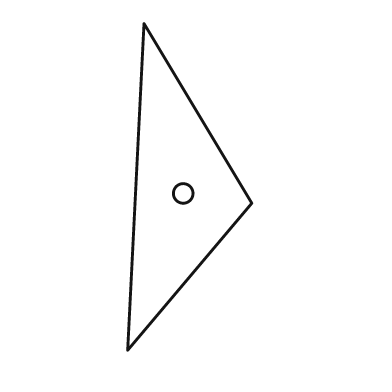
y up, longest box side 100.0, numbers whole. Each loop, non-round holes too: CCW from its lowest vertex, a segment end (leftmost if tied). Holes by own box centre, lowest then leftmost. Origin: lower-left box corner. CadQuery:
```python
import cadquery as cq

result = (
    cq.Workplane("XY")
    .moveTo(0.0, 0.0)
    .lineTo(38.0, 45.0)
    .lineTo(5.0, 100.0)
    .close()
    .moveTo(17.0, 48.0)
    .circle(3.0)
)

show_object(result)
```